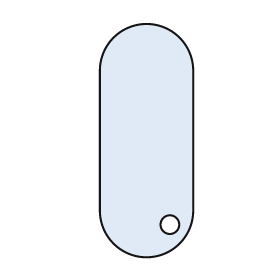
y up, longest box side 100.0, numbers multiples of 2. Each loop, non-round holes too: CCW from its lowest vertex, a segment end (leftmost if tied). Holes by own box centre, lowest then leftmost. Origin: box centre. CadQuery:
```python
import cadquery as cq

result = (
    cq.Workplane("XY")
    .moveTo(-20.0, -30.0)
    .threePointArc((0.0, -50.0), (20.0, -30.0))
    .lineTo(20.0, 30.0)
    .threePointArc((0.0, 50.0), (-20.0, 30.0))
    .close()
    .moveTo(10.0, -36.0)
    .circle(4.0)
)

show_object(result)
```